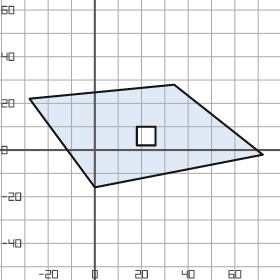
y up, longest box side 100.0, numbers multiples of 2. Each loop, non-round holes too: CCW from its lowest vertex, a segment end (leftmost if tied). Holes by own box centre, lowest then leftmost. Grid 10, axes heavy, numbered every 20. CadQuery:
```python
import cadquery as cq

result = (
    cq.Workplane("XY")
    .moveTo(0.0, -16.0)
    .lineTo(72.0, -2.0)
    .lineTo(34.0, 28.0)
    .lineTo(-28.0, 22.0)
    .close()
    .moveTo(18.0, 2.0)
    .lineTo(26.0, 2.0)
    .lineTo(26.0, 10.0)
    .lineTo(18.0, 10.0)
    .close()
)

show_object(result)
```